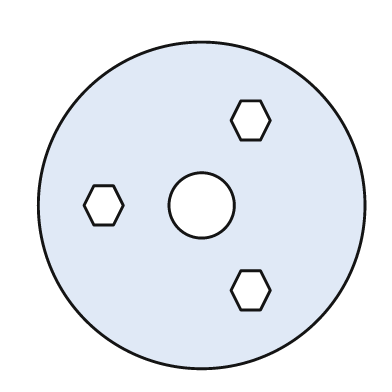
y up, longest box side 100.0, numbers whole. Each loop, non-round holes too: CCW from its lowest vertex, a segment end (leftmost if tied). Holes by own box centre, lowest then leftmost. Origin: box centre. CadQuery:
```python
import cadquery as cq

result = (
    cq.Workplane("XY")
    .moveTo(0.0, 0.0)
    .circle(50.0)
    .moveTo(12.0, -32.0)
    .lineTo(18.0, -32.0)
    .lineTo(21.0, -26.0)
    .lineTo(18.0, -20.0)
    .lineTo(12.0, -20.0)
    .lineTo(9.0, -26.0)
    .close()
    .moveTo(-33.0, -6.0)
    .lineTo(-27.0, -6.0)
    .lineTo(-24.0, 0.0)
    .lineTo(-27.0, 6.0)
    .lineTo(-33.0, 6.0)
    .lineTo(-36.0, 0.0)
    .close()
    .moveTo(0.0, 0.0)
    .circle(10.0)
    .moveTo(12.0, 20.0)
    .lineTo(18.0, 20.0)
    .lineTo(21.0, 26.0)
    .lineTo(18.0, 32.0)
    .lineTo(12.0, 32.0)
    .lineTo(9.0, 26.0)
    .close()
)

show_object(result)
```